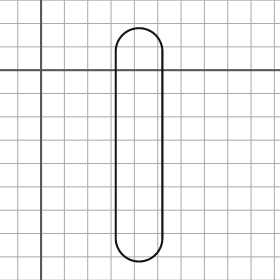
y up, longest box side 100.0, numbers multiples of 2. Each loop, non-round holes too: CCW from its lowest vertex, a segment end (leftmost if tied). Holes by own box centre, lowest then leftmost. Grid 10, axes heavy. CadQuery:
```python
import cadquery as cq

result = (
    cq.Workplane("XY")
    .moveTo(32.0, -72.0)
    .threePointArc((42.0, -82.0), (52.0, -72.0))
    .lineTo(52.0, 8.0)
    .threePointArc((42.0, 18.0), (32.0, 8.0))
    .close()
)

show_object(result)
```